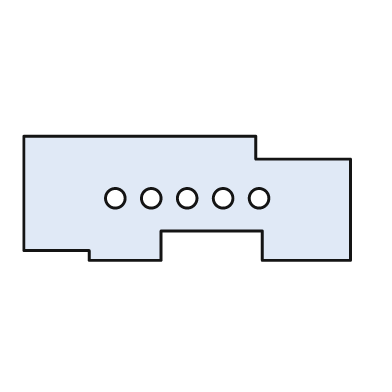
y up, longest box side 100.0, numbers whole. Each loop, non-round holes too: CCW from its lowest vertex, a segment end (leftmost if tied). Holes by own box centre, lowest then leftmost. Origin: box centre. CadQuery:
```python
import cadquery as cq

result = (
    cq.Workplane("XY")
    .moveTo(-30.0, -19.0)
    .lineTo(-8.0, -19.0)
    .lineTo(-8.0, -10.0)
    .lineTo(23.0, -10.0)
    .lineTo(23.0, -19.0)
    .lineTo(50.0, -19.0)
    .lineTo(50.0, 12.0)
    .lineTo(21.0, 12.0)
    .lineTo(21.0, 19.0)
    .lineTo(-50.0, 19.0)
    .lineTo(-50.0, -16.0)
    .lineTo(-30.0, -16.0)
    .close()
    .moveTo(-22.0, 0.0)
    .circle(3.0)
    .moveTo(-11.0, 0.0)
    .circle(3.0)
    .moveTo(0.0, 0.0)
    .circle(3.0)
    .moveTo(11.0, 0.0)
    .circle(3.0)
    .moveTo(22.0, 0.0)
    .circle(3.0)
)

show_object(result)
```